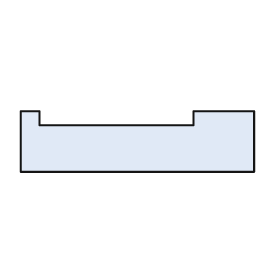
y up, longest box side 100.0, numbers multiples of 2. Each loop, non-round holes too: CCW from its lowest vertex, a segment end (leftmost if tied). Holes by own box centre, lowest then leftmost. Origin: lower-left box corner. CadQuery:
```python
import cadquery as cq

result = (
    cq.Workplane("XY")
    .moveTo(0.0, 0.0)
    .lineTo(100.0, 0.0)
    .lineTo(100.0, 26.0)
    .lineTo(74.0, 26.0)
    .lineTo(74.0, 20.0)
    .lineTo(8.0, 20.0)
    .lineTo(8.0, 26.0)
    .lineTo(0.0, 26.0)
    .close()
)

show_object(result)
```